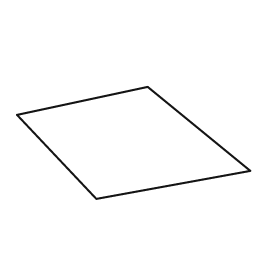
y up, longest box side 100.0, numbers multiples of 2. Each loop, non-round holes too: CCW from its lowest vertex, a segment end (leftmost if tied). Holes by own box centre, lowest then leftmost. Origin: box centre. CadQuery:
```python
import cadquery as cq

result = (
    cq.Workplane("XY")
    .moveTo(-16.0, -24.0)
    .lineTo(50.0, -12.0)
    .lineTo(6.0, 24.0)
    .lineTo(-50.0, 12.0)
    .close()
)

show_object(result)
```